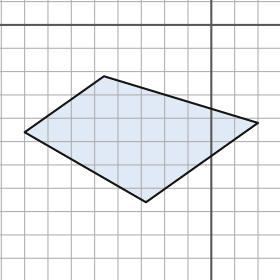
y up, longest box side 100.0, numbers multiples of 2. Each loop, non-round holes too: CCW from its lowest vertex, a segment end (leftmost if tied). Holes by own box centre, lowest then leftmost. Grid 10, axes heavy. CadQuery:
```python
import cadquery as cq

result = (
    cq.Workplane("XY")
    .moveTo(-28.0, -76.0)
    .lineTo(20.0, -42.0)
    .lineTo(-46.0, -22.0)
    .lineTo(-80.0, -46.0)
    .close()
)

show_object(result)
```